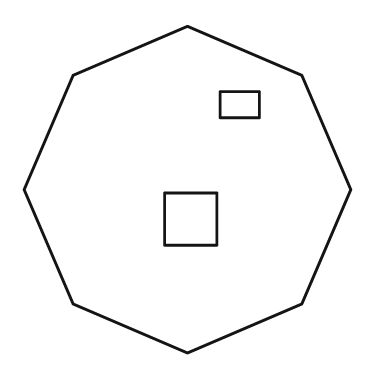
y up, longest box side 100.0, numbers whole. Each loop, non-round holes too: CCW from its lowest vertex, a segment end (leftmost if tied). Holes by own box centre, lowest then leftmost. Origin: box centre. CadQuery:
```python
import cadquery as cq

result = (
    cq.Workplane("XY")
    .moveTo(0.0, -50.0)
    .lineTo(35.0, -35.0)
    .lineTo(50.0, 0.0)
    .lineTo(35.0, 35.0)
    .lineTo(0.0, 50.0)
    .lineTo(-35.0, 35.0)
    .lineTo(-50.0, 0.0)
    .lineTo(-35.0, -35.0)
    .close()
    .moveTo(-7.0, -17.0)
    .lineTo(9.0, -17.0)
    .lineTo(9.0, -1.0)
    .lineTo(-7.0, -1.0)
    .close()
    .moveTo(10.0, 22.0)
    .lineTo(22.0, 22.0)
    .lineTo(22.0, 30.0)
    .lineTo(10.0, 30.0)
    .close()
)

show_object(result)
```